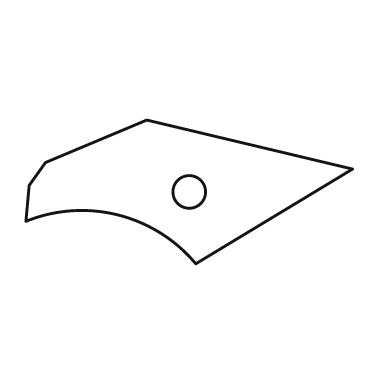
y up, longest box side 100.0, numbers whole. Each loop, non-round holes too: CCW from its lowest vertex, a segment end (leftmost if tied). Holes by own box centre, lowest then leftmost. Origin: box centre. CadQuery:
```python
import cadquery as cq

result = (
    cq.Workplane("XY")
    .moveTo(2.0, -22.0)
    .lineTo(50.0, 7.0)
    .lineTo(-13.0, 22.0)
    .lineTo(-44.0, 9.0)
    .lineTo(-49.0, 2.0)
    .lineTo(-50.0, -9.0)
    .threePointArc((-22.0, -7.0), (2.0, -22.0))
    .close()
    .moveTo(0.0, 0.0)
    .circle(5.0)
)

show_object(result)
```